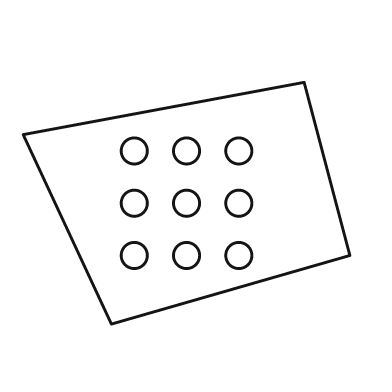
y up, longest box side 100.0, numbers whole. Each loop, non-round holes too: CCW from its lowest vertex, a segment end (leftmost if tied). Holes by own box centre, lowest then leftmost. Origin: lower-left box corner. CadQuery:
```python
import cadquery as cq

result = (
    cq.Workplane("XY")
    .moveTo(27.0, 0.0)
    .lineTo(100.0, 21.0)
    .lineTo(86.0, 74.0)
    .lineTo(0.0, 58.0)
    .close()
    .moveTo(34.0, 21.0)
    .circle(4.0)
    .moveTo(50.0, 21.0)
    .circle(4.0)
    .moveTo(66.0, 21.0)
    .circle(4.0)
    .moveTo(34.0, 37.0)
    .circle(4.0)
    .moveTo(50.0, 37.0)
    .circle(4.0)
    .moveTo(66.0, 37.0)
    .circle(4.0)
    .moveTo(34.0, 53.0)
    .circle(4.0)
    .moveTo(50.0, 53.0)
    .circle(4.0)
    .moveTo(66.0, 53.0)
    .circle(4.0)
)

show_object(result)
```